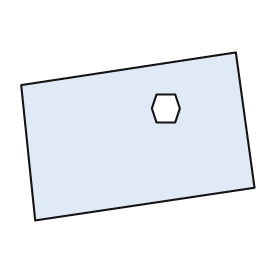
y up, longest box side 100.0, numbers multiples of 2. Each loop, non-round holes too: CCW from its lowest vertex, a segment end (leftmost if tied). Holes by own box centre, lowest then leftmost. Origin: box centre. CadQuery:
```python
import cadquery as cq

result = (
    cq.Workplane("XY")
    .moveTo(-44.0, -36.0)
    .lineTo(50.0, -22.0)
    .lineTo(42.0, 36.0)
    .lineTo(-50.0, 22.0)
    .close()
    .moveTo(8.0, 6.0)
    .lineTo(16.0, 6.0)
    .lineTo(18.0, 12.0)
    .lineTo(16.0, 18.0)
    .lineTo(8.0, 18.0)
    .lineTo(6.0, 12.0)
    .close()
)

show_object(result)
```